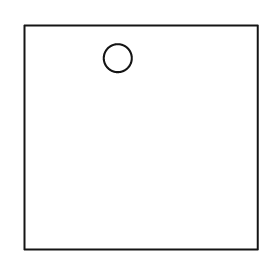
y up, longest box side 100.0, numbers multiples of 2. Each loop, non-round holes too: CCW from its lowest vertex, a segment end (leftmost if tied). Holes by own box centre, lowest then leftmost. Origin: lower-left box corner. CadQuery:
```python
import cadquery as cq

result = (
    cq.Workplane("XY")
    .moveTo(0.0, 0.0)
    .lineTo(100.0, 0.0)
    .lineTo(100.0, 96.0)
    .lineTo(0.0, 96.0)
    .close()
    .moveTo(40.0, 82.0)
    .circle(6.0)
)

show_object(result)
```